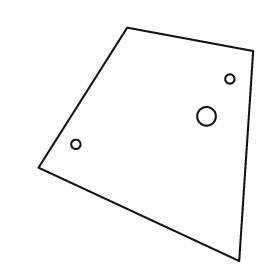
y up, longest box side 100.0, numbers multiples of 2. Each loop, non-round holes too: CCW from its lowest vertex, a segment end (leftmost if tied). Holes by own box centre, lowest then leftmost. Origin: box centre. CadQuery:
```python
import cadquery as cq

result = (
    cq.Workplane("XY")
    .moveTo(40.0, -50.0)
    .lineTo(46.0, 40.0)
    .lineTo(-8.0, 50.0)
    .lineTo(-46.0, -10.0)
    .close()
    .moveTo(-30.0, 0.0)
    .circle(2.0)
    .moveTo(26.0, 12.0)
    .circle(4.0)
    .moveTo(36.0, 28.0)
    .circle(2.0)
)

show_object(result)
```